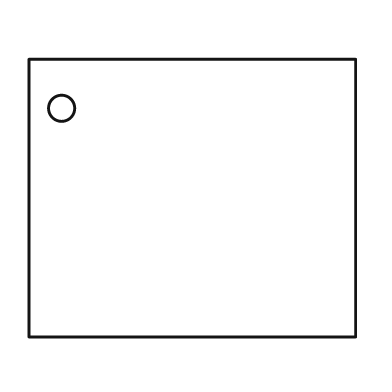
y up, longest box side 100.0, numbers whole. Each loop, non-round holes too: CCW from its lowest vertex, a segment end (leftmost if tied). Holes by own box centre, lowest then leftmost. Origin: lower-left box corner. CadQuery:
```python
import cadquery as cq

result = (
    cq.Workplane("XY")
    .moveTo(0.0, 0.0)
    .lineTo(100.0, 0.0)
    .lineTo(100.0, 85.0)
    .lineTo(0.0, 85.0)
    .close()
    .moveTo(10.0, 70.0)
    .circle(4.0)
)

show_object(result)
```